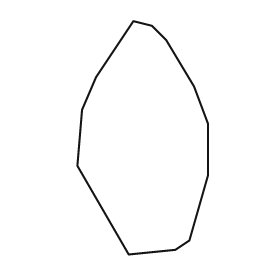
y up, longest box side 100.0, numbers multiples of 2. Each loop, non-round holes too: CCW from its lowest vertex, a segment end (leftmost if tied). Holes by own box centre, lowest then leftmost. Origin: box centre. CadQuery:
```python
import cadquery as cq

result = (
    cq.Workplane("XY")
    .moveTo(-6.0, -50.0)
    .lineTo(14.0, -48.0)
    .lineTo(20.0, -44.0)
    .lineTo(28.0, -16.0)
    .lineTo(28.0, 6.0)
    .lineTo(22.0, 22.0)
    .lineTo(10.0, 42.0)
    .lineTo(4.0, 48.0)
    .lineTo(-4.0, 50.0)
    .lineTo(-20.0, 26.0)
    .lineTo(-26.0, 12.0)
    .lineTo(-28.0, -12.0)
    .close()
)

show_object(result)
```